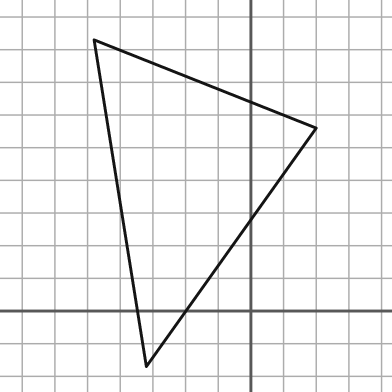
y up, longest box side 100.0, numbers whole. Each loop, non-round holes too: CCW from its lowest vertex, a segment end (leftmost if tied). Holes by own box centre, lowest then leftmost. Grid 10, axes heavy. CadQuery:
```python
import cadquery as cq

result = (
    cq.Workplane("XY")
    .moveTo(-32.0, -17.0)
    .lineTo(20.0, 56.0)
    .lineTo(-48.0, 83.0)
    .close()
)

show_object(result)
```